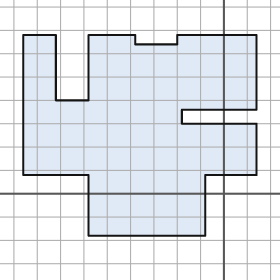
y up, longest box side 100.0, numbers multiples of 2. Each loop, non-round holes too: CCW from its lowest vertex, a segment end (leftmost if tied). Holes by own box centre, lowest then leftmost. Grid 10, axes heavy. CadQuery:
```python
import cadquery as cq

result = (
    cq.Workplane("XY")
    .moveTo(-58.0, -18.0)
    .lineTo(-8.0, -18.0)
    .lineTo(-8.0, 8.0)
    .lineTo(14.0, 8.0)
    .lineTo(14.0, 30.0)
    .lineTo(-18.0, 30.0)
    .lineTo(-18.0, 36.0)
    .lineTo(14.0, 36.0)
    .lineTo(14.0, 68.0)
    .lineTo(-20.0, 68.0)
    .lineTo(-20.0, 64.0)
    .lineTo(-38.0, 64.0)
    .lineTo(-38.0, 68.0)
    .lineTo(-58.0, 68.0)
    .lineTo(-58.0, 40.0)
    .lineTo(-72.0, 40.0)
    .lineTo(-72.0, 68.0)
    .lineTo(-86.0, 68.0)
    .lineTo(-86.0, 8.0)
    .lineTo(-58.0, 8.0)
    .close()
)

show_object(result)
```